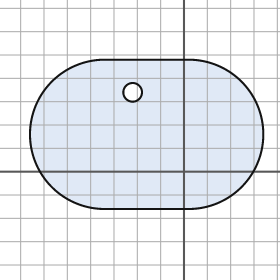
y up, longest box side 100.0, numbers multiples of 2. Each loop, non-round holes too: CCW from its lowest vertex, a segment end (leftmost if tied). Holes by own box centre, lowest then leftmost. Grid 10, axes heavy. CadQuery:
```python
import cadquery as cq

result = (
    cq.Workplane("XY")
    .moveTo(-34.0, -16.0)
    .lineTo(2.0, -16.0)
    .threePointArc((34.0, 16.0), (2.0, 48.0))
    .lineTo(-34.0, 48.0)
    .threePointArc((-66.0, 16.0), (-34.0, -16.0))
    .close()
    .moveTo(-22.0, 34.0)
    .circle(4.0)
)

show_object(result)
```